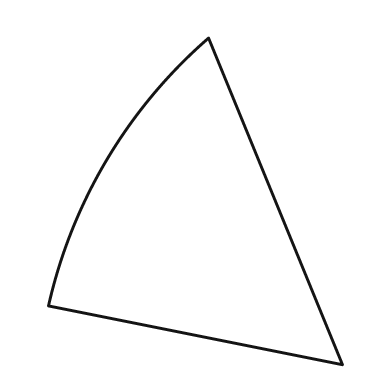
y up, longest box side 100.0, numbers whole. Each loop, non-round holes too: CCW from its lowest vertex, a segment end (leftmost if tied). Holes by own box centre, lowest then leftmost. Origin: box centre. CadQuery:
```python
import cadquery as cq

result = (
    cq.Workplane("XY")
    .moveTo(45.0, -50.0)
    .lineTo(4.0, 50.0)
    .threePointArc((-27.0, 13.0), (-45.0, -32.0))
    .close()
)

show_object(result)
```